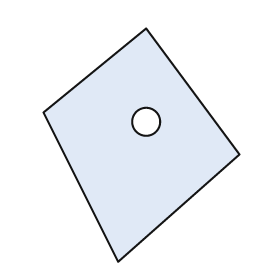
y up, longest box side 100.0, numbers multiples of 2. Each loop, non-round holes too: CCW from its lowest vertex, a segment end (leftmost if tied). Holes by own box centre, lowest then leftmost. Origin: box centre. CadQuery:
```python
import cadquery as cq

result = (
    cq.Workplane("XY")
    .moveTo(-10.0, -50.0)
    .lineTo(42.0, -4.0)
    .lineTo(2.0, 50.0)
    .lineTo(-42.0, 14.0)
    .close()
    .moveTo(2.0, 10.0)
    .circle(6.0)
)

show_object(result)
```